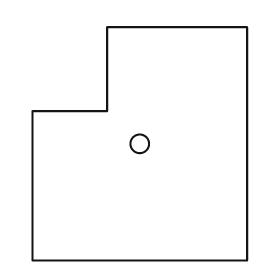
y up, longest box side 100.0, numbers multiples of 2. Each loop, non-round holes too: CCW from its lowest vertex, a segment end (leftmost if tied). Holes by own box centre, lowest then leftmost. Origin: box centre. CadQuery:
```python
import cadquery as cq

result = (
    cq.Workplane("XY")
    .moveTo(-46.0, -50.0)
    .lineTo(46.0, -50.0)
    .lineTo(46.0, 50.0)
    .lineTo(-14.0, 50.0)
    .lineTo(-14.0, 14.0)
    .lineTo(-46.0, 14.0)
    .close()
    .moveTo(0.0, 0.0)
    .circle(4.0)
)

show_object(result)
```